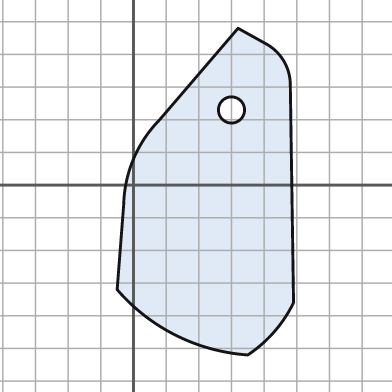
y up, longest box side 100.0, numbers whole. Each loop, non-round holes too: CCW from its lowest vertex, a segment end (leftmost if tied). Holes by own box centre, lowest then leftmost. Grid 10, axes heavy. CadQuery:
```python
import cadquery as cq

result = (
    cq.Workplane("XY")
    .moveTo(35.0, -52.0)
    .threePointArc((43.0, -45.0), (49.0, -36.0))
    .lineTo(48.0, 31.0)
    .threePointArc((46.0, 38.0), (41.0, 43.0))
    .lineTo(32.0, 48.0)
    .lineTo(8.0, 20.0)
    .threePointArc((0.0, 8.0), (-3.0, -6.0))
    .lineTo(-5.0, -32.0)
    .threePointArc((13.0, -46.0), (35.0, -52.0))
    .close()
    .moveTo(30.0, 23.0)
    .circle(4.0)
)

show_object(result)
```